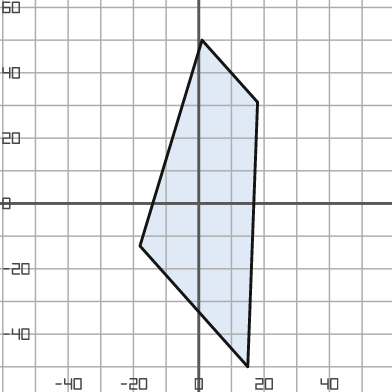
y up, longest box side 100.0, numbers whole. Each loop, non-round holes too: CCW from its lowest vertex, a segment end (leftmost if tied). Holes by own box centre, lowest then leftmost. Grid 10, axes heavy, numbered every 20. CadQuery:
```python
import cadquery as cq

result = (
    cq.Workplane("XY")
    .moveTo(15.0, -50.0)
    .lineTo(18.0, 31.0)
    .lineTo(1.0, 50.0)
    .lineTo(-18.0, -13.0)
    .close()
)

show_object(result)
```